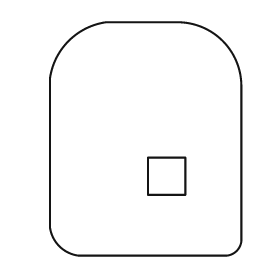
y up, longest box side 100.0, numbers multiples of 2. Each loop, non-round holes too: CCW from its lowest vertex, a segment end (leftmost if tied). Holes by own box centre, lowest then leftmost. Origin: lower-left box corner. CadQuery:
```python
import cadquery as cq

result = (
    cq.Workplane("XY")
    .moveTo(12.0, 0.0)
    .lineTo(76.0, 0.0)
    .threePointArc((80.0, 2.0), (82.0, 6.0))
    .lineTo(82.0, 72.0)
    .threePointArc((74.0, 92.0), (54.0, 100.0))
    .lineTo(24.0, 100.0)
    .threePointArc((8.0, 92.0), (0.0, 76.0))
    .lineTo(0.0, 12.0)
    .threePointArc((4.0, 4.0), (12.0, 0.0))
    .close()
    .moveTo(42.0, 26.0)
    .lineTo(58.0, 26.0)
    .lineTo(58.0, 42.0)
    .lineTo(42.0, 42.0)
    .close()
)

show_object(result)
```